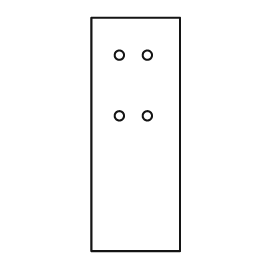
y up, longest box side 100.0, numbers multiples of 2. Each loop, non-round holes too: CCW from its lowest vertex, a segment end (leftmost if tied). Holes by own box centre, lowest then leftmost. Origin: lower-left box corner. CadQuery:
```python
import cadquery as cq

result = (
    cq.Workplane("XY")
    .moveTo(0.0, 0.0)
    .lineTo(38.0, 0.0)
    .lineTo(38.0, 100.0)
    .lineTo(0.0, 100.0)
    .close()
    .moveTo(12.0, 58.0)
    .circle(2.0)
    .moveTo(24.0, 58.0)
    .circle(2.0)
    .moveTo(12.0, 84.0)
    .circle(2.0)
    .moveTo(24.0, 84.0)
    .circle(2.0)
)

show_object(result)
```